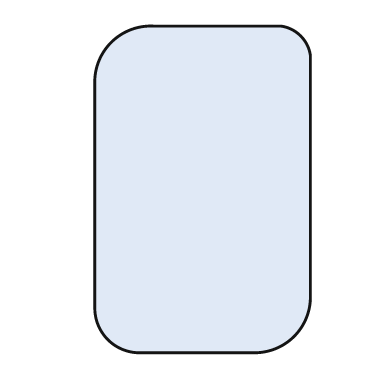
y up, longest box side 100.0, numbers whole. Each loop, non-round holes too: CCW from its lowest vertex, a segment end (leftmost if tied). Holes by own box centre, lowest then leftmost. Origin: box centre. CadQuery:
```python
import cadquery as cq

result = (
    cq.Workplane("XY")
    .moveTo(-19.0, -50.0)
    .lineTo(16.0, -50.0)
    .threePointArc((28.0, -45.0), (33.0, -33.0))
    .lineTo(33.0, 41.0)
    .threePointArc((30.0, 47.0), (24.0, 50.0))
    .lineTo(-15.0, 50.0)
    .threePointArc((-28.0, 45.0), (-33.0, 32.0))
    .lineTo(-33.0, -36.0)
    .threePointArc((-29.0, -46.0), (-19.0, -50.0))
    .close()
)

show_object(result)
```